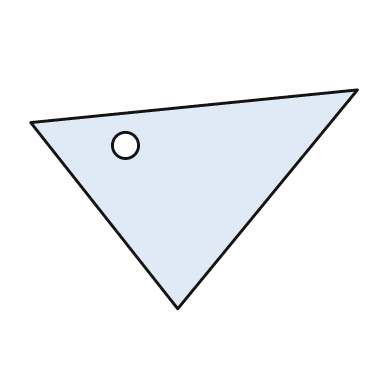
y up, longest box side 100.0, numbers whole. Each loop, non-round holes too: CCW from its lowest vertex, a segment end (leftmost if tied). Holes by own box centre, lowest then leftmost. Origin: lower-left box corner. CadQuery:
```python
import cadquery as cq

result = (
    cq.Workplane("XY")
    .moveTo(45.0, 0.0)
    .lineTo(100.0, 67.0)
    .lineTo(0.0, 57.0)
    .close()
    .moveTo(29.0, 50.0)
    .circle(4.0)
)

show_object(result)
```